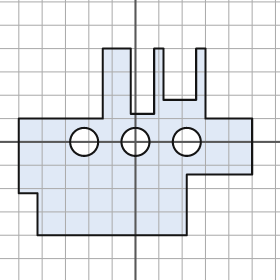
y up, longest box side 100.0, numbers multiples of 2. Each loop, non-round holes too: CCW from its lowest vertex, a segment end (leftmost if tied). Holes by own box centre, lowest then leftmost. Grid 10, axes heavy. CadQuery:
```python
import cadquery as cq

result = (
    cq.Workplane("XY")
    .moveTo(-42.0, -40.0)
    .lineTo(22.0, -40.0)
    .lineTo(22.0, -14.0)
    .lineTo(50.0, -14.0)
    .lineTo(50.0, 10.0)
    .lineTo(30.0, 10.0)
    .lineTo(30.0, 40.0)
    .lineTo(26.0, 40.0)
    .lineTo(26.0, 18.0)
    .lineTo(12.0, 18.0)
    .lineTo(12.0, 40.0)
    .lineTo(8.0, 40.0)
    .lineTo(8.0, 12.0)
    .lineTo(-2.0, 12.0)
    .lineTo(-2.0, 40.0)
    .lineTo(-14.0, 40.0)
    .lineTo(-14.0, 10.0)
    .lineTo(-50.0, 10.0)
    .lineTo(-50.0, -22.0)
    .lineTo(-42.0, -22.0)
    .close()
    .moveTo(-22.0, 0.0)
    .circle(6.0)
    .moveTo(0.0, 0.0)
    .circle(6.0)
    .moveTo(22.0, 0.0)
    .circle(6.0)
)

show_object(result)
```